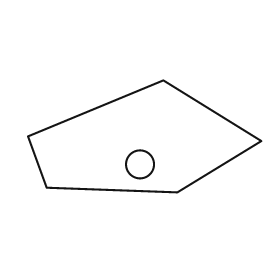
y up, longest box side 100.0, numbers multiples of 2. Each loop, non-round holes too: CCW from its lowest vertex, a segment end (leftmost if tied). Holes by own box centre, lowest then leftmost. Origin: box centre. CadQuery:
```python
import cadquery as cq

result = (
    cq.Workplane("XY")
    .moveTo(14.0, -24.0)
    .lineTo(50.0, -2.0)
    .lineTo(8.0, 24.0)
    .lineTo(-50.0, 0.0)
    .lineTo(-42.0, -22.0)
    .close()
    .moveTo(-2.0, -12.0)
    .circle(6.0)
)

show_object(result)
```